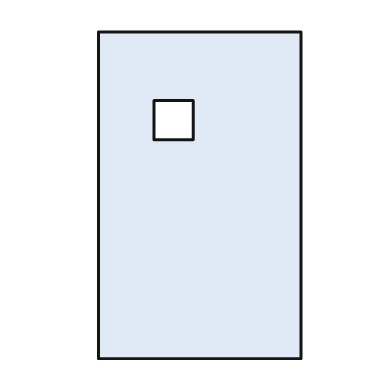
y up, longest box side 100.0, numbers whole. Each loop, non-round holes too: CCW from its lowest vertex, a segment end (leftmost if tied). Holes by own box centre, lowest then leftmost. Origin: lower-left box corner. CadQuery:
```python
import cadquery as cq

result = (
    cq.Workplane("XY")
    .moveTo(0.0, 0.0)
    .lineTo(62.0, 0.0)
    .lineTo(62.0, 100.0)
    .lineTo(0.0, 100.0)
    .close()
    .moveTo(17.0, 67.0)
    .lineTo(29.0, 67.0)
    .lineTo(29.0, 79.0)
    .lineTo(17.0, 79.0)
    .close()
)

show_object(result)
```